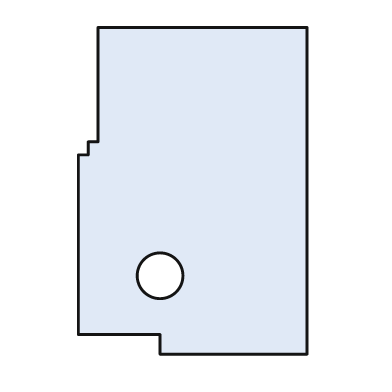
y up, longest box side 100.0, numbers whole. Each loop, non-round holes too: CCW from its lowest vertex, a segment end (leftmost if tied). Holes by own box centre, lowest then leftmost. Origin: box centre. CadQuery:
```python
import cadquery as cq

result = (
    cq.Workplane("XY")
    .moveTo(-10.0, -50.0)
    .lineTo(35.0, -50.0)
    .lineTo(35.0, 50.0)
    .lineTo(-29.0, 50.0)
    .lineTo(-29.0, 15.0)
    .lineTo(-32.0, 15.0)
    .lineTo(-32.0, 11.0)
    .lineTo(-35.0, 11.0)
    .lineTo(-35.0, -44.0)
    .lineTo(-10.0, -44.0)
    .close()
    .moveTo(-10.0, -26.0)
    .circle(7.0)
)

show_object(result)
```